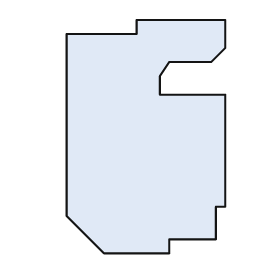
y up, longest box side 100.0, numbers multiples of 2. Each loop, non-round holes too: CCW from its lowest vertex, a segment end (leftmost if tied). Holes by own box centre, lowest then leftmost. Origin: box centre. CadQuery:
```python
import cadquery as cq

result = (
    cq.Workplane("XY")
    .moveTo(-18.0, -50.0)
    .lineTo(10.0, -50.0)
    .lineTo(10.0, -44.0)
    .lineTo(30.0, -44.0)
    .lineTo(30.0, -30.0)
    .lineTo(34.0, -30.0)
    .lineTo(34.0, 18.0)
    .lineTo(6.0, 18.0)
    .lineTo(6.0, 26.0)
    .lineTo(10.0, 32.0)
    .lineTo(28.0, 32.0)
    .lineTo(34.0, 38.0)
    .lineTo(34.0, 50.0)
    .lineTo(-4.0, 50.0)
    .lineTo(-4.0, 44.0)
    .lineTo(-34.0, 44.0)
    .lineTo(-34.0, -34.0)
    .close()
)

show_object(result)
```